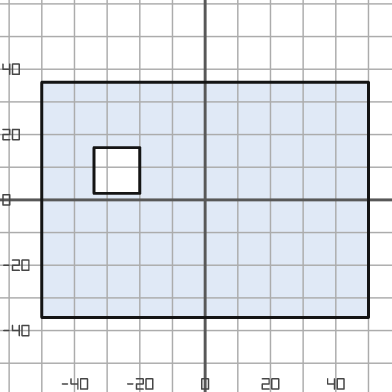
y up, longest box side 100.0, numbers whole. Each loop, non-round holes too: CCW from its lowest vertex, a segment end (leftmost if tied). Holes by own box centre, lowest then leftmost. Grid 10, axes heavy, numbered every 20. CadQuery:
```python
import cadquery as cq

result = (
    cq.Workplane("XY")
    .moveTo(-50.0, -36.0)
    .lineTo(50.0, -36.0)
    .lineTo(50.0, 36.0)
    .lineTo(-50.0, 36.0)
    .close()
    .moveTo(-34.0, 2.0)
    .lineTo(-20.0, 2.0)
    .lineTo(-20.0, 16.0)
    .lineTo(-34.0, 16.0)
    .close()
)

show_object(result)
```